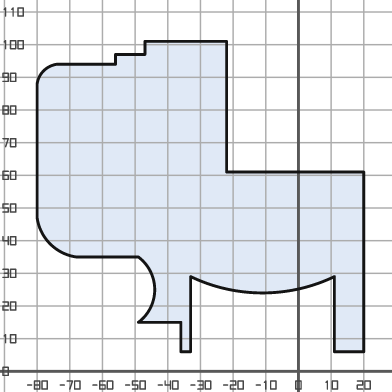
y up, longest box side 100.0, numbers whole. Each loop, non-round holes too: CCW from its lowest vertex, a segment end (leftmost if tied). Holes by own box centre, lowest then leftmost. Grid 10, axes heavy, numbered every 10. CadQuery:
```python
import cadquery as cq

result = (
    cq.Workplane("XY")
    .moveTo(-36.0, 6.0)
    .lineTo(-33.0, 6.0)
    .lineTo(-33.0, 29.0)
    .threePointArc((-11.0, 24.0), (11.0, 29.0))
    .lineTo(11.0, 6.0)
    .lineTo(20.0, 6.0)
    .lineTo(20.0, 61.0)
    .lineTo(-22.0, 61.0)
    .lineTo(-22.0, 101.0)
    .lineTo(-47.0, 101.0)
    .lineTo(-47.0, 97.0)
    .lineTo(-56.0, 97.0)
    .lineTo(-56.0, 94.0)
    .lineTo(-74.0, 94.0)
    .threePointArc((-78.0, 92.0), (-80.0, 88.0))
    .lineTo(-80.0, 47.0)
    .threePointArc((-76.0, 39.0), (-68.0, 35.0))
    .lineTo(-49.0, 35.0)
    .threePointArc((-44.0, 25.0), (-49.0, 15.0))
    .lineTo(-36.0, 15.0)
    .close()
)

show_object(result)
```